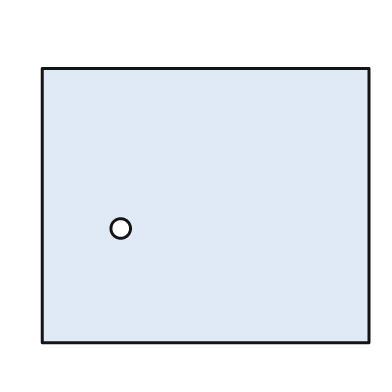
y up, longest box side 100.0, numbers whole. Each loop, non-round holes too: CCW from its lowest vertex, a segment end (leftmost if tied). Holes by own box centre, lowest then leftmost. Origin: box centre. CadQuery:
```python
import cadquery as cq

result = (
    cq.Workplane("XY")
    .moveTo(-50.0, -42.0)
    .lineTo(50.0, -42.0)
    .lineTo(50.0, 42.0)
    .lineTo(-50.0, 42.0)
    .close()
    .moveTo(-26.0, -7.0)
    .circle(3.0)
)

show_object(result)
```